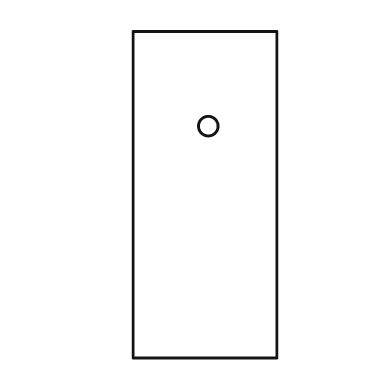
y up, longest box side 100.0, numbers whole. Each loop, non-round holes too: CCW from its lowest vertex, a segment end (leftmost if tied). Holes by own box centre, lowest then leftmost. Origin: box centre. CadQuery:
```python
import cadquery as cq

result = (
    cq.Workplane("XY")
    .moveTo(-22.0, -50.0)
    .lineTo(22.0, -50.0)
    .lineTo(22.0, 50.0)
    .lineTo(-22.0, 50.0)
    .close()
    .moveTo(1.0, 21.0)
    .circle(3.0)
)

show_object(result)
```